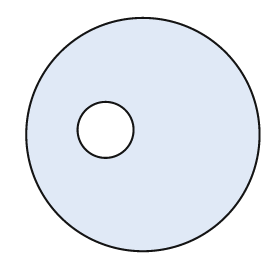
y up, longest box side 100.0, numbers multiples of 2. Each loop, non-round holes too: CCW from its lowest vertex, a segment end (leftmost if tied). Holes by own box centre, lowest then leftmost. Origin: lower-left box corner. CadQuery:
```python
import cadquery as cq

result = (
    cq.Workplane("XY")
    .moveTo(50.0, 50.0)
    .circle(50.0)
    .moveTo(34.0, 52.0)
    .circle(12.0)
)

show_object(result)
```